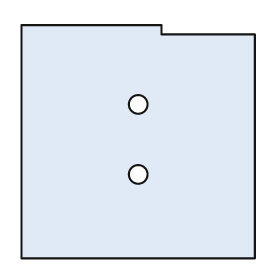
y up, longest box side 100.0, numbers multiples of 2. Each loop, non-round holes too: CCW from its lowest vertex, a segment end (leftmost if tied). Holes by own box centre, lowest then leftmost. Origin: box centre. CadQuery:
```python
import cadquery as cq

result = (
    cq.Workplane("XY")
    .moveTo(-50.0, -50.0)
    .lineTo(50.0, -50.0)
    .lineTo(50.0, 46.0)
    .lineTo(10.0, 46.0)
    .lineTo(10.0, 50.0)
    .lineTo(-50.0, 50.0)
    .close()
    .moveTo(0.0, -14.0)
    .circle(4.0)
    .moveTo(0.0, 16.0)
    .circle(4.0)
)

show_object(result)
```